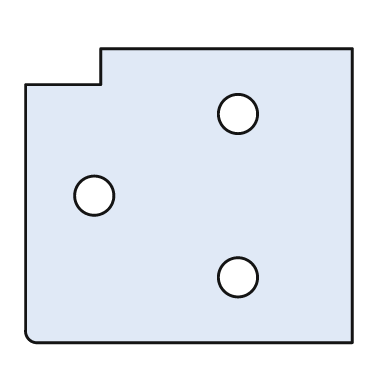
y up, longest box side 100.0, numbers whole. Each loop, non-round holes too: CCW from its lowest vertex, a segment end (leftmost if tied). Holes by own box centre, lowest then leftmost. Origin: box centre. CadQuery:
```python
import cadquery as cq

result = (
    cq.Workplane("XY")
    .moveTo(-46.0, -45.0)
    .lineTo(50.0, -45.0)
    .lineTo(50.0, 45.0)
    .lineTo(-27.0, 45.0)
    .lineTo(-27.0, 34.0)
    .lineTo(-50.0, 34.0)
    .lineTo(-50.0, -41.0)
    .threePointArc((-49.0, -44.0), (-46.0, -45.0))
    .close()
    .moveTo(15.0, -25.0)
    .circle(6.0)
    .moveTo(-29.0, 0.0)
    .circle(6.0)
    .moveTo(15.0, 25.0)
    .circle(6.0)
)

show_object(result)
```